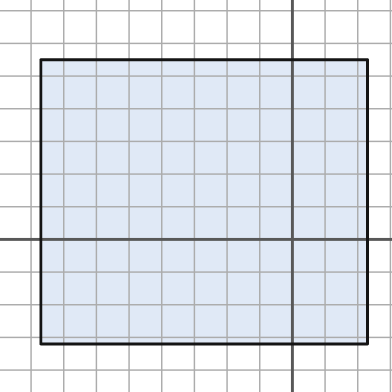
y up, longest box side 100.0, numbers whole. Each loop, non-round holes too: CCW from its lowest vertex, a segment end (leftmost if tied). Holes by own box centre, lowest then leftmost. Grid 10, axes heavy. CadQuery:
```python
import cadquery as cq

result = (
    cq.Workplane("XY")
    .moveTo(-77.0, -32.0)
    .lineTo(23.0, -32.0)
    .lineTo(23.0, 55.0)
    .lineTo(-77.0, 55.0)
    .close()
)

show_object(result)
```